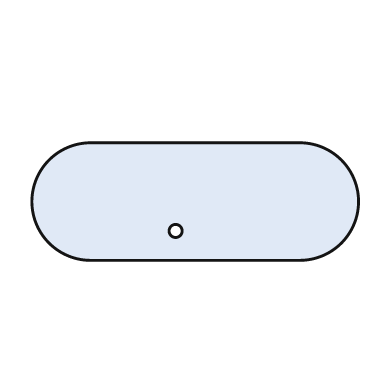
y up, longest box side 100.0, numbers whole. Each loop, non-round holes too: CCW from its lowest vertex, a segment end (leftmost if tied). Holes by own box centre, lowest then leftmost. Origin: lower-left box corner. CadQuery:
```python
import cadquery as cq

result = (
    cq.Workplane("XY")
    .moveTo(18.0, 0.0)
    .lineTo(82.0, 0.0)
    .threePointArc((100.0, 18.0), (82.0, 36.0))
    .lineTo(18.0, 36.0)
    .threePointArc((0.0, 18.0), (18.0, 0.0))
    .close()
    .moveTo(44.0, 9.0)
    .circle(2.0)
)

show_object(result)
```